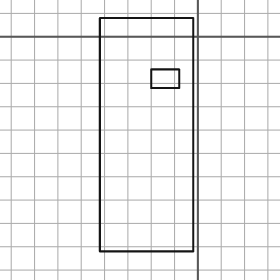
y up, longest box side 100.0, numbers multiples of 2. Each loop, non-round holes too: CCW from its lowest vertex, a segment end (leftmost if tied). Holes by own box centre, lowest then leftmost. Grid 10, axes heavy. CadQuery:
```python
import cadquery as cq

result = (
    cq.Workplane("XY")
    .moveTo(-42.0, -92.0)
    .lineTo(-2.0, -92.0)
    .lineTo(-2.0, 8.0)
    .lineTo(-42.0, 8.0)
    .close()
    .moveTo(-20.0, -22.0)
    .lineTo(-8.0, -22.0)
    .lineTo(-8.0, -14.0)
    .lineTo(-20.0, -14.0)
    .close()
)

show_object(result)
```